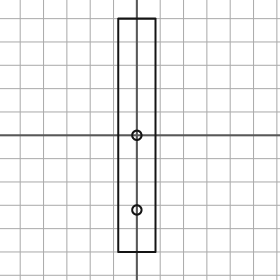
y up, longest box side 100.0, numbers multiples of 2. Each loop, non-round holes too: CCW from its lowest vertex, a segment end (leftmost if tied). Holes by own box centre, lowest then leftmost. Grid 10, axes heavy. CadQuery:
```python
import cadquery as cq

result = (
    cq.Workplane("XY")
    .moveTo(-8.0, -50.0)
    .lineTo(8.0, -50.0)
    .lineTo(8.0, 50.0)
    .lineTo(-8.0, 50.0)
    .close()
    .moveTo(0.0, -32.0)
    .circle(2.0)
    .moveTo(0.0, 0.0)
    .circle(2.0)
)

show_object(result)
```